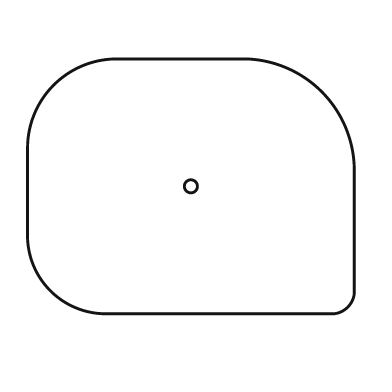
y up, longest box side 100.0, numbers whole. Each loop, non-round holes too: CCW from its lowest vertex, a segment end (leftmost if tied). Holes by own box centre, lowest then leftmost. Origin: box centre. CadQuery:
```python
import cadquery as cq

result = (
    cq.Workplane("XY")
    .moveTo(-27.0, -39.0)
    .lineTo(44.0, -39.0)
    .threePointArc((48.0, -37.0), (50.0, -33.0))
    .lineTo(50.0, 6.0)
    .threePointArc((40.0, 29.0), (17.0, 39.0))
    .lineTo(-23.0, 39.0)
    .threePointArc((-42.0, 31.0), (-50.0, 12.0))
    .lineTo(-50.0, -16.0)
    .threePointArc((-43.0, -32.0), (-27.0, -39.0))
    .close()
    .moveTo(0.0, 0.0)
    .circle(2.0)
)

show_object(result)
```